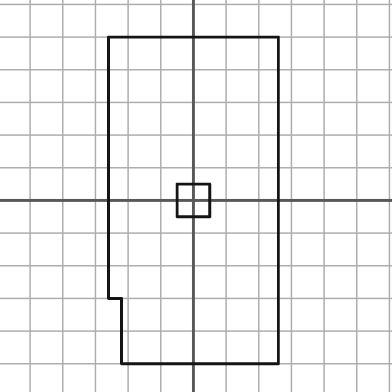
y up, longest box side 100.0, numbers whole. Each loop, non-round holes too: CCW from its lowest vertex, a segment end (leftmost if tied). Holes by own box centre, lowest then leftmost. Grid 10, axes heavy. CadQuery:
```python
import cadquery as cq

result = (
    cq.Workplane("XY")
    .moveTo(-22.0, -50.0)
    .lineTo(26.0, -50.0)
    .lineTo(26.0, 50.0)
    .lineTo(-26.0, 50.0)
    .lineTo(-26.0, -30.0)
    .lineTo(-22.0, -30.0)
    .close()
    .moveTo(-5.0, -5.0)
    .lineTo(5.0, -5.0)
    .lineTo(5.0, 5.0)
    .lineTo(-5.0, 5.0)
    .close()
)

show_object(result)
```